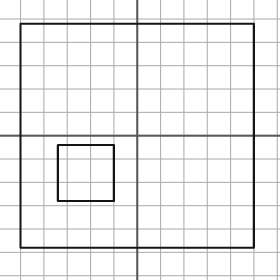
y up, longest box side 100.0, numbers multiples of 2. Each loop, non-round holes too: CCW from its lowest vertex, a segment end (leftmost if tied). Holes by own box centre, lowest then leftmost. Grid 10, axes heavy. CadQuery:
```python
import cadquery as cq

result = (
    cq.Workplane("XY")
    .moveTo(-50.0, -48.0)
    .lineTo(50.0, -48.0)
    .lineTo(50.0, 48.0)
    .lineTo(-50.0, 48.0)
    .close()
    .moveTo(-34.0, -28.0)
    .lineTo(-10.0, -28.0)
    .lineTo(-10.0, -4.0)
    .lineTo(-34.0, -4.0)
    .close()
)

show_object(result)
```